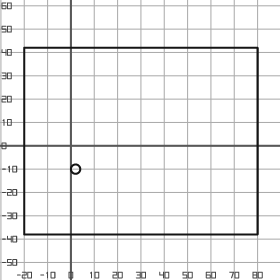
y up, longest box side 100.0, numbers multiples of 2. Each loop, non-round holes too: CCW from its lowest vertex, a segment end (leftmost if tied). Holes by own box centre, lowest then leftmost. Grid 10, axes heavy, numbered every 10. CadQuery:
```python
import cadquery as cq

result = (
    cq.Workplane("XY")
    .moveTo(-20.0, -38.0)
    .lineTo(80.0, -38.0)
    .lineTo(80.0, 42.0)
    .lineTo(-20.0, 42.0)
    .close()
    .moveTo(2.0, -10.0)
    .circle(2.0)
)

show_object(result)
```